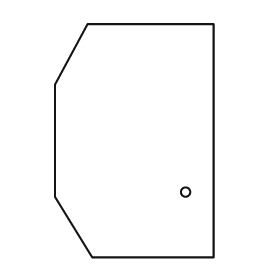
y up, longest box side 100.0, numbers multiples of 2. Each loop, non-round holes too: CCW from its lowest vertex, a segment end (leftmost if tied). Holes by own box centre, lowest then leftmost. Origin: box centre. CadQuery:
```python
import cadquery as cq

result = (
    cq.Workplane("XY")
    .moveTo(-18.0, -50.0)
    .lineTo(34.0, -50.0)
    .lineTo(34.0, 50.0)
    .lineTo(-20.0, 50.0)
    .lineTo(-34.0, 24.0)
    .lineTo(-34.0, -24.0)
    .close()
    .moveTo(22.0, -22.0)
    .circle(2.0)
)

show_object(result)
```